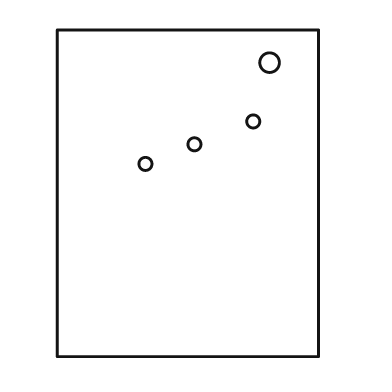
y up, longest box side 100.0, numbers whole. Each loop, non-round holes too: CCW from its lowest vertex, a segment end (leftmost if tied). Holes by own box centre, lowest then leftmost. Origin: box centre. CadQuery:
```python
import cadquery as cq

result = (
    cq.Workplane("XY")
    .moveTo(-40.0, -50.0)
    .lineTo(40.0, -50.0)
    .lineTo(40.0, 50.0)
    .lineTo(-40.0, 50.0)
    .close()
    .moveTo(-13.0, 9.0)
    .circle(2.0)
    .moveTo(2.0, 15.0)
    .circle(2.0)
    .moveTo(20.0, 22.0)
    .circle(2.0)
    .moveTo(25.0, 40.0)
    .circle(3.0)
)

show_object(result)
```